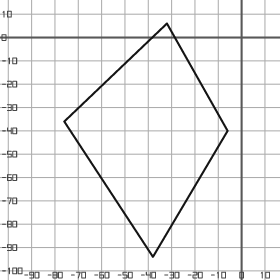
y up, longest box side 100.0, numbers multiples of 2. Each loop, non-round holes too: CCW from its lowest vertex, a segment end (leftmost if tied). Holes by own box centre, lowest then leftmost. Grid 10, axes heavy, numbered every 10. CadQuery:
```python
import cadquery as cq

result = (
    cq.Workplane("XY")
    .moveTo(-38.0, -94.0)
    .lineTo(-6.0, -40.0)
    .lineTo(-32.0, 6.0)
    .lineTo(-76.0, -36.0)
    .close()
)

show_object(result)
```